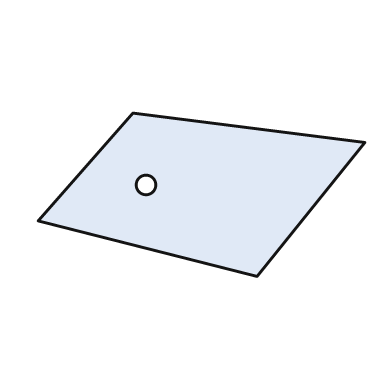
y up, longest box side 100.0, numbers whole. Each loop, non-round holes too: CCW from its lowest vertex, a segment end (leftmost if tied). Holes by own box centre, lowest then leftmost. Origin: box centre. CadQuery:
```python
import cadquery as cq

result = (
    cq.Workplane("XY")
    .moveTo(17.0, -25.0)
    .lineTo(50.0, 16.0)
    .lineTo(-21.0, 25.0)
    .lineTo(-50.0, -8.0)
    .close()
    .moveTo(-17.0, 3.0)
    .circle(3.0)
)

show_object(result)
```